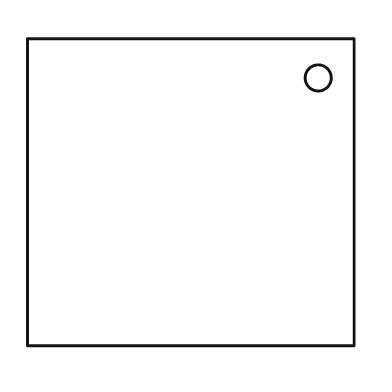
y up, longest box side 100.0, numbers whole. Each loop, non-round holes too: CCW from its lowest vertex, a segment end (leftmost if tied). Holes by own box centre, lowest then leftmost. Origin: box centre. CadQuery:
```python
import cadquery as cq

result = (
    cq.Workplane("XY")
    .moveTo(-50.0, -47.0)
    .lineTo(50.0, -47.0)
    .lineTo(50.0, 47.0)
    .lineTo(-50.0, 47.0)
    .close()
    .moveTo(39.0, 35.0)
    .circle(4.0)
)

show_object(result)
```